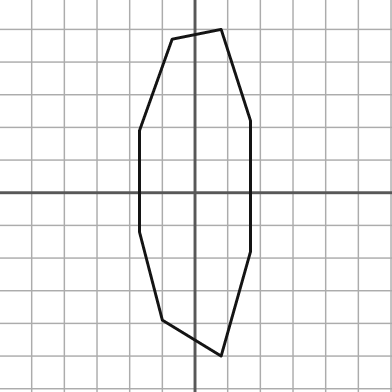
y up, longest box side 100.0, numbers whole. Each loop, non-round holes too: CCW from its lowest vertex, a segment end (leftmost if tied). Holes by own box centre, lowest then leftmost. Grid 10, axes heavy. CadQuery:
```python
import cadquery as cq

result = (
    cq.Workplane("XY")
    .moveTo(8.0, -50.0)
    .lineTo(17.0, -18.0)
    .lineTo(17.0, 22.0)
    .lineTo(8.0, 50.0)
    .lineTo(-7.0, 47.0)
    .lineTo(-17.0, 19.0)
    .lineTo(-17.0, -12.0)
    .lineTo(-10.0, -39.0)
    .close()
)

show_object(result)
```